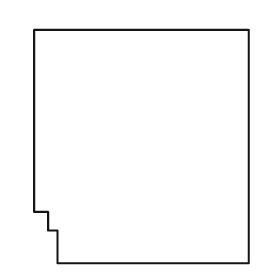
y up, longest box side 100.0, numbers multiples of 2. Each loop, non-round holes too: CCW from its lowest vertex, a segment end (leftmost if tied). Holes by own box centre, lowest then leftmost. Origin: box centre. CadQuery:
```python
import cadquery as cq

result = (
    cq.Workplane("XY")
    .moveTo(-36.0, -50.0)
    .lineTo(46.0, -50.0)
    .lineTo(46.0, 50.0)
    .lineTo(-46.0, 50.0)
    .lineTo(-46.0, -28.0)
    .lineTo(-40.0, -28.0)
    .lineTo(-40.0, -36.0)
    .lineTo(-36.0, -36.0)
    .close()
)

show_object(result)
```